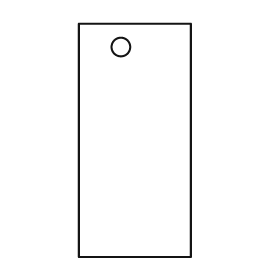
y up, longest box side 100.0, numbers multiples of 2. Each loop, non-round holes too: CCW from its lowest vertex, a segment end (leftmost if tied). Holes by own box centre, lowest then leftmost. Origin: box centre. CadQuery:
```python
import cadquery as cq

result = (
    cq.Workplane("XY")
    .moveTo(-24.0, -50.0)
    .lineTo(24.0, -50.0)
    .lineTo(24.0, 50.0)
    .lineTo(-24.0, 50.0)
    .close()
    .moveTo(-6.0, 40.0)
    .circle(4.0)
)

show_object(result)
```